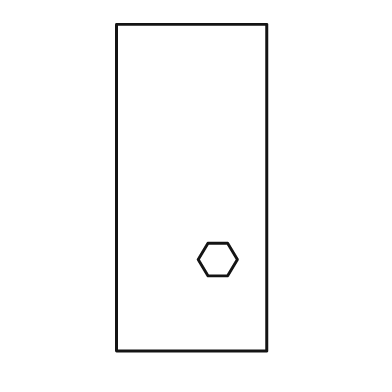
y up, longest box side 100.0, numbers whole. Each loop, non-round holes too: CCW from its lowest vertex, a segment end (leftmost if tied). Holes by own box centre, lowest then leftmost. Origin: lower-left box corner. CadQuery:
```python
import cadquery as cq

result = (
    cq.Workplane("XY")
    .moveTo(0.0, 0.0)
    .lineTo(46.0, 0.0)
    .lineTo(46.0, 100.0)
    .lineTo(0.0, 100.0)
    .close()
    .moveTo(28.0, 23.0)
    .lineTo(34.0, 23.0)
    .lineTo(37.0, 28.0)
    .lineTo(34.0, 33.0)
    .lineTo(28.0, 33.0)
    .lineTo(25.0, 28.0)
    .close()
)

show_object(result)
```